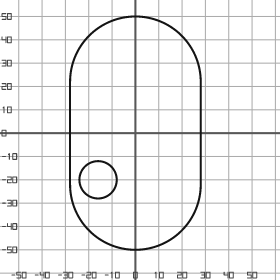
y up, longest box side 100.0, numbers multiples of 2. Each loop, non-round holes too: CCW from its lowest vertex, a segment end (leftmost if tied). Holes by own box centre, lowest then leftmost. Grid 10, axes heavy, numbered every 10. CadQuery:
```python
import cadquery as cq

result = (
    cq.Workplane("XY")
    .moveTo(-28.0, -22.0)
    .threePointArc((0.0, -50.0), (28.0, -22.0))
    .lineTo(28.0, 22.0)
    .threePointArc((0.0, 50.0), (-28.0, 22.0))
    .close()
    .moveTo(-16.0, -20.0)
    .circle(8.0)
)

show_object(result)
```